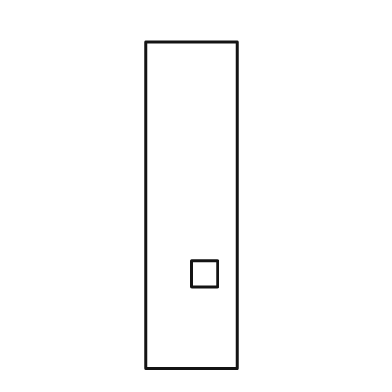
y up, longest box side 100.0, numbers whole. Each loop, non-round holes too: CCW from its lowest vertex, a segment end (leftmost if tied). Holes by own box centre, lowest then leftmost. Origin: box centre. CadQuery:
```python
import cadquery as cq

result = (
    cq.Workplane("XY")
    .moveTo(-14.0, -50.0)
    .lineTo(14.0, -50.0)
    .lineTo(14.0, 50.0)
    .lineTo(-14.0, 50.0)
    .close()
    .moveTo(0.0, -25.0)
    .lineTo(8.0, -25.0)
    .lineTo(8.0, -17.0)
    .lineTo(0.0, -17.0)
    .close()
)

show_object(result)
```